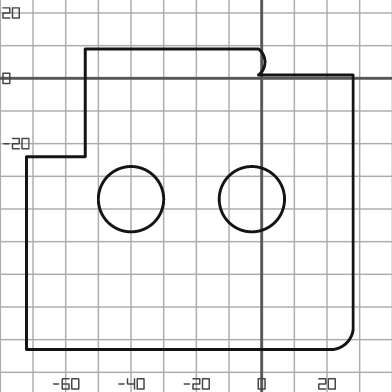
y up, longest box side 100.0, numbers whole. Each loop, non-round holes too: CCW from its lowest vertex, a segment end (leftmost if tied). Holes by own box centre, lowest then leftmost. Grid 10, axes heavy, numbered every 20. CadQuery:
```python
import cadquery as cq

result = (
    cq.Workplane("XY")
    .moveTo(-72.0, -83.0)
    .lineTo(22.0, -83.0)
    .threePointArc((26.0, -81.0), (28.0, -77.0))
    .lineTo(28.0, 1.0)
    .lineTo(-1.0, 1.0)
    .threePointArc((1.0, 5.0), (-1.0, 9.0))
    .lineTo(-54.0, 9.0)
    .lineTo(-54.0, -24.0)
    .lineTo(-72.0, -24.0)
    .close()
    .moveTo(-40.0, -37.0)
    .circle(10.0)
    .moveTo(-3.0, -37.0)
    .circle(10.0)
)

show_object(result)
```